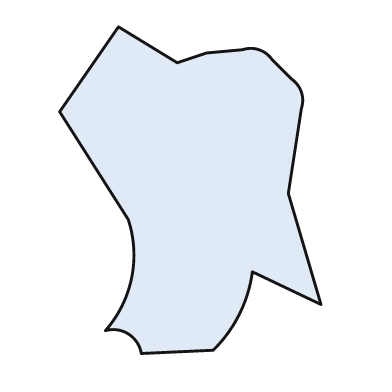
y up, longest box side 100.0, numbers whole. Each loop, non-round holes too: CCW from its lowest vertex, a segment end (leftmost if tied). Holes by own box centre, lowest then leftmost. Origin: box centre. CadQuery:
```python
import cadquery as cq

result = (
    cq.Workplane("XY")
    .moveTo(-15.0, -50.0)
    .lineTo(7.0, -49.0)
    .threePointArc((15.0, -38.0), (19.0, -25.0))
    .lineTo(40.0, -35.0)
    .lineTo(30.0, -1.0)
    .lineTo(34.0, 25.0)
    .threePointArc((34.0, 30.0), (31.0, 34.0))
    .lineTo(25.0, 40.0)
    .threePointArc((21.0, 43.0), (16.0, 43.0))
    .lineTo(5.0, 42.0)
    .lineTo(-4.0, 39.0)
    .lineTo(-22.0, 50.0)
    .lineTo(-40.0, 24.0)
    .lineTo(-19.0, -9.0)
    .threePointArc((-18.0, -27.0), (-26.0, -43.0))
    .threePointArc((-19.0, -44.0), (-15.0, -50.0))
    .close()
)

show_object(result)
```